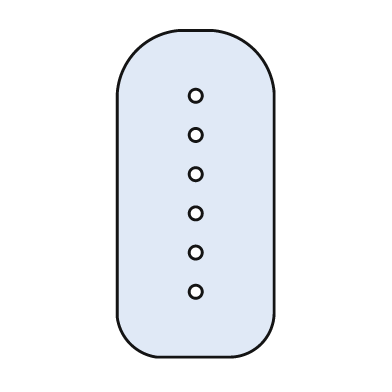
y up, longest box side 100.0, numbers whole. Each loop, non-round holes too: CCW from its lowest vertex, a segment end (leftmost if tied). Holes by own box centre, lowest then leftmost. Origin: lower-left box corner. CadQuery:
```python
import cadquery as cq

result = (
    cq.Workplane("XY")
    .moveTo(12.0, 0.0)
    .lineTo(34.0, 0.0)
    .threePointArc((44.0, 4.0), (48.0, 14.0))
    .lineTo(48.0, 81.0)
    .threePointArc((42.0, 94.0), (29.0, 100.0))
    .lineTo(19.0, 100.0)
    .threePointArc((6.0, 94.0), (0.0, 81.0))
    .lineTo(0.0, 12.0)
    .threePointArc((4.0, 4.0), (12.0, 0.0))
    .close()
    .moveTo(24.0, 20.0)
    .circle(2.0)
    .moveTo(24.0, 32.0)
    .circle(2.0)
    .moveTo(24.0, 44.0)
    .circle(2.0)
    .moveTo(24.0, 56.0)
    .circle(2.0)
    .moveTo(24.0, 68.0)
    .circle(2.0)
    .moveTo(24.0, 80.0)
    .circle(2.0)
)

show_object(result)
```